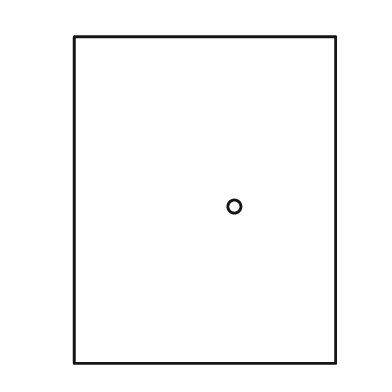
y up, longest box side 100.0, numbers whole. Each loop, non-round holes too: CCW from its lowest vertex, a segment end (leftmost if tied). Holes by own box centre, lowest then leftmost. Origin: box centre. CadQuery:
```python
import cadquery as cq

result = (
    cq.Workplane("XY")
    .moveTo(-40.0, -50.0)
    .lineTo(40.0, -50.0)
    .lineTo(40.0, 50.0)
    .lineTo(-40.0, 50.0)
    .close()
    .moveTo(9.0, -2.0)
    .circle(2.0)
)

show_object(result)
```